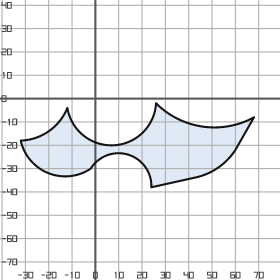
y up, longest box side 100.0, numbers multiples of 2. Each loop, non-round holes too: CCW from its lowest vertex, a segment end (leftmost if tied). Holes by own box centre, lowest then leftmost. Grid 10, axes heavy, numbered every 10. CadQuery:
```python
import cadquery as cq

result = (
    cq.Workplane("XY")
    .moveTo(24.0, -38.0)
    .lineTo(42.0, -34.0)
    .threePointArc((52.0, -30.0), (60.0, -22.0))
    .lineTo(68.0, -8.0)
    .threePointArc((46.0, -12.0), (26.0, -2.0))
    .threePointArc((8.0, -20.0), (-12.0, -4.0))
    .threePointArc((-20.0, -14.0), (-32.0, -18.0))
    .threePointArc((-20.0, -32.0), (-2.0, -30.0))
    .threePointArc((14.0, -24.0), (24.0, -38.0))
    .close()
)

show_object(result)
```